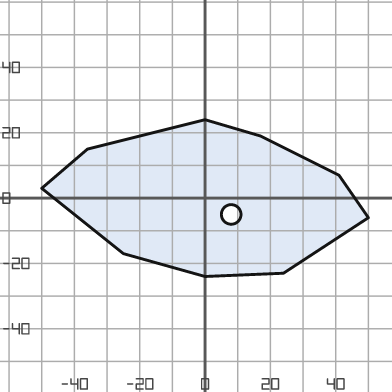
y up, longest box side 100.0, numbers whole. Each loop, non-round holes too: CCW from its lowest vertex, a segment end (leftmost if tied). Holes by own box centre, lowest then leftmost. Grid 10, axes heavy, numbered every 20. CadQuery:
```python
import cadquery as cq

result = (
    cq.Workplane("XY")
    .moveTo(0.0, -24.0)
    .lineTo(24.0, -23.0)
    .lineTo(50.0, -6.0)
    .lineTo(41.0, 7.0)
    .lineTo(17.0, 19.0)
    .lineTo(0.0, 24.0)
    .lineTo(-36.0, 15.0)
    .lineTo(-50.0, 3.0)
    .lineTo(-25.0, -17.0)
    .close()
    .moveTo(8.0, -5.0)
    .circle(3.0)
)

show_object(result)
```